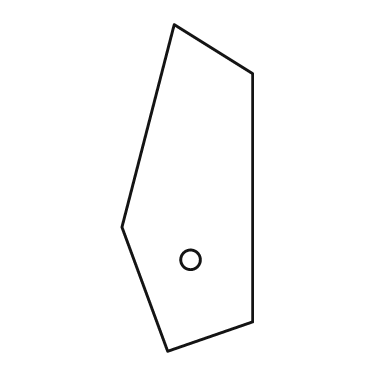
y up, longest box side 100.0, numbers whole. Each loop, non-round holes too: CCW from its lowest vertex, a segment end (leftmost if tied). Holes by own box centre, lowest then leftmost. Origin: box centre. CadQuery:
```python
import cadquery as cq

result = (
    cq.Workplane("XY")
    .moveTo(-6.0, -50.0)
    .lineTo(20.0, -41.0)
    .lineTo(20.0, 35.0)
    .lineTo(-4.0, 50.0)
    .lineTo(-20.0, -12.0)
    .close()
    .moveTo(1.0, -22.0)
    .circle(3.0)
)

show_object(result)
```